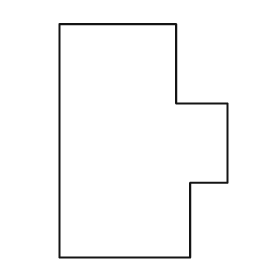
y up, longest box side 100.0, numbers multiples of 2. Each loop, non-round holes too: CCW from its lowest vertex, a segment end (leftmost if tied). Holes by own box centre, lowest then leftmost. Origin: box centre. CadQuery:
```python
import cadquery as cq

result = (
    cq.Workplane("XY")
    .moveTo(-36.0, -50.0)
    .lineTo(20.0, -50.0)
    .lineTo(20.0, -18.0)
    .lineTo(36.0, -18.0)
    .lineTo(36.0, 16.0)
    .lineTo(14.0, 16.0)
    .lineTo(14.0, 50.0)
    .lineTo(-36.0, 50.0)
    .close()
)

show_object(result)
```